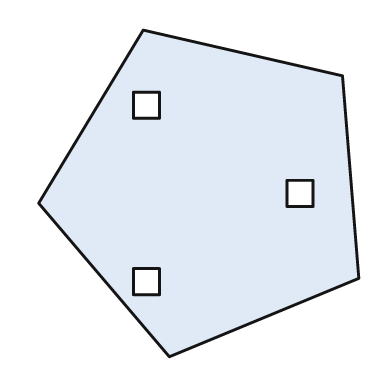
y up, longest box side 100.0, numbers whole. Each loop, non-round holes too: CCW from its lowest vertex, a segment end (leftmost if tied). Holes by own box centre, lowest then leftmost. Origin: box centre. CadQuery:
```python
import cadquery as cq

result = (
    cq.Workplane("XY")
    .moveTo(-9.0, -50.0)
    .lineTo(49.0, -26.0)
    .lineTo(44.0, 36.0)
    .lineTo(-17.0, 50.0)
    .lineTo(-49.0, -3.0)
    .close()
    .moveTo(-20.0, -31.0)
    .lineTo(-12.0, -31.0)
    .lineTo(-12.0, -23.0)
    .lineTo(-20.0, -23.0)
    .close()
    .moveTo(27.0, -4.0)
    .lineTo(35.0, -4.0)
    .lineTo(35.0, 4.0)
    .lineTo(27.0, 4.0)
    .close()
    .moveTo(-20.0, 23.0)
    .lineTo(-12.0, 23.0)
    .lineTo(-12.0, 31.0)
    .lineTo(-20.0, 31.0)
    .close()
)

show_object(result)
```